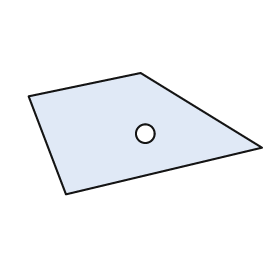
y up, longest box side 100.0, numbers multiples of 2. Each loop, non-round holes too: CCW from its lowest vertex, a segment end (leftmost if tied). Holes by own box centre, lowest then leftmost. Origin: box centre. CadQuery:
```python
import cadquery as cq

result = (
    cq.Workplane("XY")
    .moveTo(-34.0, -26.0)
    .lineTo(50.0, -6.0)
    .lineTo(-2.0, 26.0)
    .lineTo(-50.0, 16.0)
    .close()
    .moveTo(0.0, 0.0)
    .circle(4.0)
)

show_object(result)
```